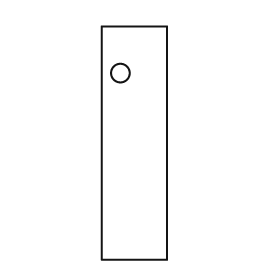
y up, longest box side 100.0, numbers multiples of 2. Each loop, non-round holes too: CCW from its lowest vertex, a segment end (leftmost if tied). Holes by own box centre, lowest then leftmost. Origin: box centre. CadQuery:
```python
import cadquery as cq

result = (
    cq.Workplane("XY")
    .moveTo(-14.0, -50.0)
    .lineTo(14.0, -50.0)
    .lineTo(14.0, 50.0)
    .lineTo(-14.0, 50.0)
    .close()
    .moveTo(-6.0, 30.0)
    .circle(4.0)
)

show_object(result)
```